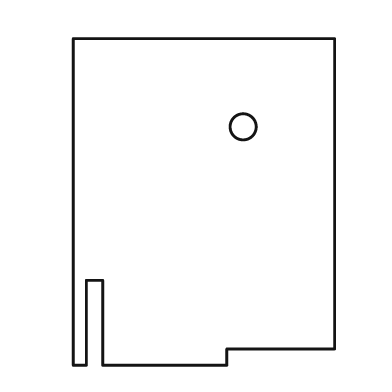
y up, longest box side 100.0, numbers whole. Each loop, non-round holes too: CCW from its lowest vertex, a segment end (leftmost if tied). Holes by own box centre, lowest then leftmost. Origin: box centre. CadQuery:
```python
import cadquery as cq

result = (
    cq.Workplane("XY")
    .moveTo(-40.0, -50.0)
    .lineTo(-36.0, -50.0)
    .lineTo(-36.0, -24.0)
    .lineTo(-31.0, -24.0)
    .lineTo(-31.0, -50.0)
    .lineTo(7.0, -50.0)
    .lineTo(7.0, -45.0)
    .lineTo(40.0, -45.0)
    .lineTo(40.0, 50.0)
    .lineTo(-40.0, 50.0)
    .close()
    .moveTo(12.0, 23.0)
    .circle(4.0)
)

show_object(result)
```